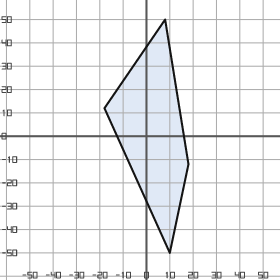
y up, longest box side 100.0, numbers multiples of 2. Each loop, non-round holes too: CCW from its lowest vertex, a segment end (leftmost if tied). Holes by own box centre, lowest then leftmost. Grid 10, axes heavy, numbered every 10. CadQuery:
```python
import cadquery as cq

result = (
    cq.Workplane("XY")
    .moveTo(10.0, -50.0)
    .lineTo(18.0, -12.0)
    .lineTo(8.0, 50.0)
    .lineTo(-18.0, 12.0)
    .close()
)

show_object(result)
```